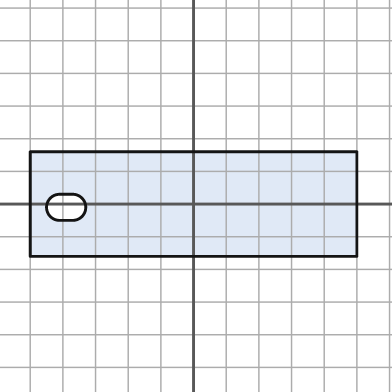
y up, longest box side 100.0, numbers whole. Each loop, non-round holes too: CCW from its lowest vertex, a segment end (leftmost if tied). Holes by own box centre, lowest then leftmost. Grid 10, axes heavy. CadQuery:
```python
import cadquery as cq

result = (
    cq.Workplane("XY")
    .moveTo(-50.0, -16.0)
    .lineTo(50.0, -16.0)
    .lineTo(50.0, 16.0)
    .lineTo(-50.0, 16.0)
    .close()
    .moveTo(-41.0, -5.0)
    .lineTo(-37.0, -5.0)
    .threePointArc((-33.0, -1.0), (-37.0, 3.0))
    .lineTo(-41.0, 3.0)
    .threePointArc((-45.0, -1.0), (-41.0, -5.0))
    .close()
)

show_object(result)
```